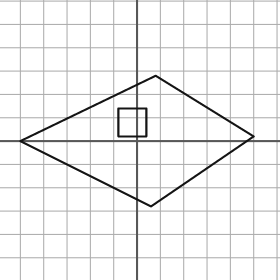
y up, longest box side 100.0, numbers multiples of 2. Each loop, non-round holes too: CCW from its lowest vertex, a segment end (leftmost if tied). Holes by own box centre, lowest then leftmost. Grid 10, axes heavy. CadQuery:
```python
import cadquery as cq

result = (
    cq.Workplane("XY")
    .moveTo(6.0, -28.0)
    .lineTo(50.0, 2.0)
    .lineTo(8.0, 28.0)
    .lineTo(-50.0, 0.0)
    .close()
    .moveTo(-8.0, 2.0)
    .lineTo(4.0, 2.0)
    .lineTo(4.0, 14.0)
    .lineTo(-8.0, 14.0)
    .close()
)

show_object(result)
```